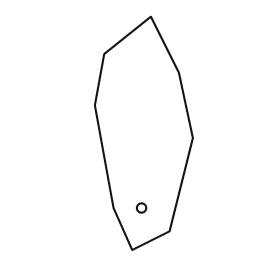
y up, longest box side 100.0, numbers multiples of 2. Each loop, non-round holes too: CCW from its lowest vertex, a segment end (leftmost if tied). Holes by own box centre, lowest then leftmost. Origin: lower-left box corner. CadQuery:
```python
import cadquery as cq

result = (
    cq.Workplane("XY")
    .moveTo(16.0, 0.0)
    .lineTo(32.0, 8.0)
    .lineTo(42.0, 48.0)
    .lineTo(36.0, 76.0)
    .lineTo(24.0, 100.0)
    .lineTo(4.0, 84.0)
    .lineTo(0.0, 62.0)
    .lineTo(8.0, 18.0)
    .close()
    .moveTo(20.0, 18.0)
    .circle(2.0)
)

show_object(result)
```